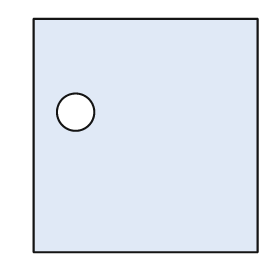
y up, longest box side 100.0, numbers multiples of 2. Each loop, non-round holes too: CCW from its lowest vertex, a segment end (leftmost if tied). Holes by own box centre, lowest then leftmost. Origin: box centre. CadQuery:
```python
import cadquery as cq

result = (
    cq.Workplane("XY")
    .moveTo(-48.0, -50.0)
    .lineTo(48.0, -50.0)
    .lineTo(48.0, 50.0)
    .lineTo(-48.0, 50.0)
    .close()
    .moveTo(-30.0, 10.0)
    .circle(8.0)
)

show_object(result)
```